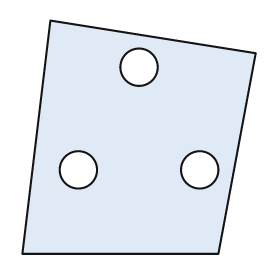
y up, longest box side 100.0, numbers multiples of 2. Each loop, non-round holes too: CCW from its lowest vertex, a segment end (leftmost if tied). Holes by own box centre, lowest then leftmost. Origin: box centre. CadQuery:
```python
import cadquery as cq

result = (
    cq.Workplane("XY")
    .moveTo(-50.0, -50.0)
    .lineTo(34.0, -50.0)
    .lineTo(50.0, 36.0)
    .lineTo(-38.0, 50.0)
    .close()
    .moveTo(-26.0, -14.0)
    .circle(8.0)
    .moveTo(26.0, -14.0)
    .circle(8.0)
    .moveTo(0.0, 30.0)
    .circle(8.0)
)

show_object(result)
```